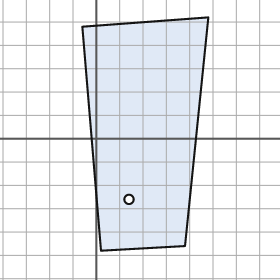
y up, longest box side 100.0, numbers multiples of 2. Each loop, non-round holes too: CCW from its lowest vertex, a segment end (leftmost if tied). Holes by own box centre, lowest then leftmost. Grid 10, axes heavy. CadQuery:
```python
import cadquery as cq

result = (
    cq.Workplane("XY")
    .moveTo(2.0, -48.0)
    .lineTo(38.0, -46.0)
    .lineTo(48.0, 52.0)
    .lineTo(-6.0, 48.0)
    .close()
    .moveTo(14.0, -26.0)
    .circle(2.0)
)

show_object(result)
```